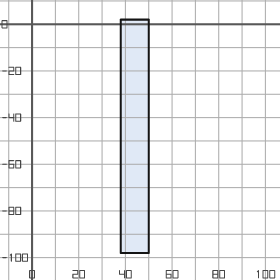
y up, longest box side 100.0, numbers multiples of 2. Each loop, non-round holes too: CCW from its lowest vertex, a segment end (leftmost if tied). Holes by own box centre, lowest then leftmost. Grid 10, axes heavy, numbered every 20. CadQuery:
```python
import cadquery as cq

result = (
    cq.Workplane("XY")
    .moveTo(38.0, -98.0)
    .lineTo(50.0, -98.0)
    .lineTo(50.0, 2.0)
    .lineTo(38.0, 2.0)
    .close()
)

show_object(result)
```